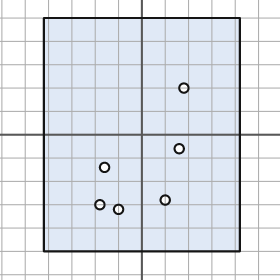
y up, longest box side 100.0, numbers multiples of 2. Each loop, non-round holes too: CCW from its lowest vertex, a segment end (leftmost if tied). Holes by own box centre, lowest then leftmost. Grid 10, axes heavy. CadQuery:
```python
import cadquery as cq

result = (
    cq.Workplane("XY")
    .moveTo(-42.0, -50.0)
    .lineTo(42.0, -50.0)
    .lineTo(42.0, 50.0)
    .lineTo(-42.0, 50.0)
    .close()
    .moveTo(-10.0, -32.0)
    .circle(2.0)
    .moveTo(-18.0, -30.0)
    .circle(2.0)
    .moveTo(10.0, -28.0)
    .circle(2.0)
    .moveTo(-16.0, -14.0)
    .circle(2.0)
    .moveTo(16.0, -6.0)
    .circle(2.0)
    .moveTo(18.0, 20.0)
    .circle(2.0)
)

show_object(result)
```